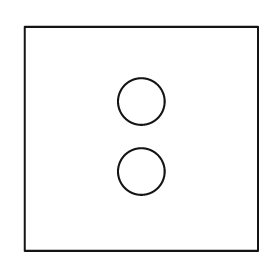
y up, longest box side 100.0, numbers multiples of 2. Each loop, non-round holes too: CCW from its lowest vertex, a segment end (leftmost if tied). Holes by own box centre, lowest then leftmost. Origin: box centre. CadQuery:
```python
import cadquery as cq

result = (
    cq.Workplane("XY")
    .moveTo(-50.0, -48.0)
    .lineTo(50.0, -48.0)
    .lineTo(50.0, 48.0)
    .lineTo(-50.0, 48.0)
    .close()
    .moveTo(0.0, -14.0)
    .circle(10.0)
    .moveTo(0.0, 16.0)
    .circle(10.0)
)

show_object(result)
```